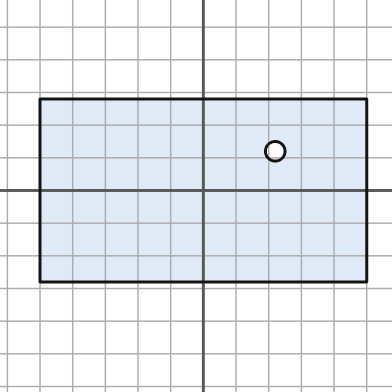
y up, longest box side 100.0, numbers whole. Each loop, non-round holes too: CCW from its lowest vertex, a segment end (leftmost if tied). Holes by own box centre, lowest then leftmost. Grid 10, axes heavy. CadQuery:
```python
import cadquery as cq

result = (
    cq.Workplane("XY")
    .moveTo(-50.0, -28.0)
    .lineTo(50.0, -28.0)
    .lineTo(50.0, 28.0)
    .lineTo(-50.0, 28.0)
    .close()
    .moveTo(22.0, 12.0)
    .circle(3.0)
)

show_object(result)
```